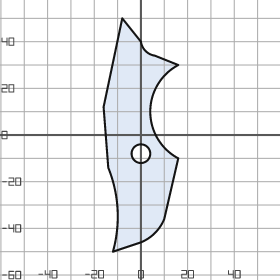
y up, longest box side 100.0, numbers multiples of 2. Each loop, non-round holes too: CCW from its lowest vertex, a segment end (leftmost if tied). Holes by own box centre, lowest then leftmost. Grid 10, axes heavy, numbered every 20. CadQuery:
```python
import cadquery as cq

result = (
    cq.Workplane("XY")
    .moveTo(-12.0, -50.0)
    .lineTo(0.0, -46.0)
    .threePointArc((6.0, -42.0), (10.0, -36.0))
    .lineTo(16.0, -10.0)
    .threePointArc((4.0, 10.0), (16.0, 30.0))
    .lineTo(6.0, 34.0)
    .threePointArc((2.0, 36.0), (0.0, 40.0))
    .lineTo(-8.0, 50.0)
    .lineTo(-16.0, 12.0)
    .lineTo(-14.0, -14.0)
    .threePointArc((-10.0, -32.0), (-12.0, -50.0))
    .close()
    .moveTo(0.0, -8.0)
    .circle(4.0)
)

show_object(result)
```